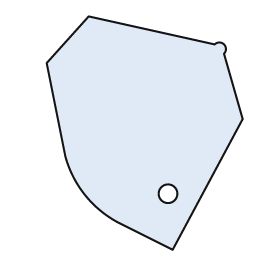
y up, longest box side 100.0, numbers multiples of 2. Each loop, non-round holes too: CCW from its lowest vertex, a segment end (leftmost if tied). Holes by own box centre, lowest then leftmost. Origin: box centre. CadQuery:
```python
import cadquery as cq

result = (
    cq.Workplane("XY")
    .moveTo(12.0, -50.0)
    .lineTo(42.0, 6.0)
    .lineTo(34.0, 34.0)
    .threePointArc((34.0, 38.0), (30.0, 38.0))
    .lineTo(-24.0, 50.0)
    .lineTo(-42.0, 30.0)
    .lineTo(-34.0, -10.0)
    .threePointArc((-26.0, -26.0), (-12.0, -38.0))
    .close()
    .moveTo(10.0, -26.0)
    .circle(4.0)
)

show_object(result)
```